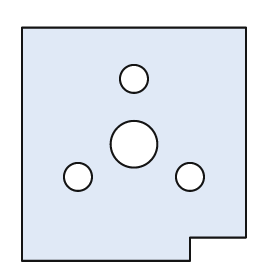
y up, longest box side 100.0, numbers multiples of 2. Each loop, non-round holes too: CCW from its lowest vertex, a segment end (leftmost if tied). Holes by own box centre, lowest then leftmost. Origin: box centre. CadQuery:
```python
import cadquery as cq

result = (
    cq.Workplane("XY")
    .moveTo(-48.0, -50.0)
    .lineTo(24.0, -50.0)
    .lineTo(24.0, -40.0)
    .lineTo(48.0, -40.0)
    .lineTo(48.0, 50.0)
    .lineTo(-48.0, 50.0)
    .close()
    .moveTo(-24.0, -14.0)
    .circle(6.0)
    .moveTo(24.0, -14.0)
    .circle(6.0)
    .moveTo(0.0, 0.0)
    .circle(10.0)
    .moveTo(0.0, 28.0)
    .circle(6.0)
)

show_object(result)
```